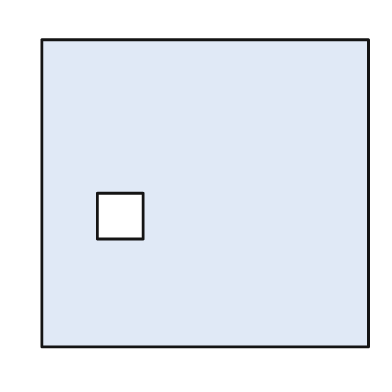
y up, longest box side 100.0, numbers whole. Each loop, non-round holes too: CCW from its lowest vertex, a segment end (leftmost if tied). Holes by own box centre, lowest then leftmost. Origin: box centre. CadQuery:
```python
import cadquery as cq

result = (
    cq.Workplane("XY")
    .moveTo(-50.0, -47.0)
    .lineTo(50.0, -47.0)
    .lineTo(50.0, 47.0)
    .lineTo(-50.0, 47.0)
    .close()
    .moveTo(-33.0, -14.0)
    .lineTo(-19.0, -14.0)
    .lineTo(-19.0, 0.0)
    .lineTo(-33.0, 0.0)
    .close()
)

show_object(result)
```